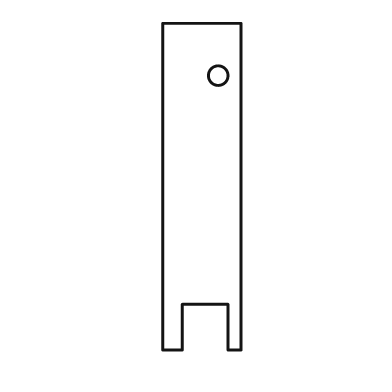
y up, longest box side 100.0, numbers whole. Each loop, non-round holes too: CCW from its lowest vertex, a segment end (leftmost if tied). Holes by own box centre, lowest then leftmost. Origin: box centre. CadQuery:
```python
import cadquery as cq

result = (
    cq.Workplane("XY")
    .moveTo(-12.0, -50.0)
    .lineTo(-6.0, -50.0)
    .lineTo(-6.0, -36.0)
    .lineTo(8.0, -36.0)
    .lineTo(8.0, -50.0)
    .lineTo(12.0, -50.0)
    .lineTo(12.0, 50.0)
    .lineTo(-12.0, 50.0)
    .close()
    .moveTo(5.0, 34.0)
    .circle(3.0)
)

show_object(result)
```